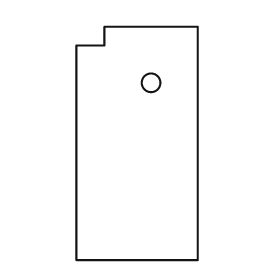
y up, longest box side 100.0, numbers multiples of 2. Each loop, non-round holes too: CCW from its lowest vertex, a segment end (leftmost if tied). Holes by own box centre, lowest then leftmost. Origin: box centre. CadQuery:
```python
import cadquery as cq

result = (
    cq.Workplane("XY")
    .moveTo(-26.0, -50.0)
    .lineTo(26.0, -50.0)
    .lineTo(26.0, 50.0)
    .lineTo(-14.0, 50.0)
    .lineTo(-14.0, 42.0)
    .lineTo(-26.0, 42.0)
    .close()
    .moveTo(6.0, 26.0)
    .circle(4.0)
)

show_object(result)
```